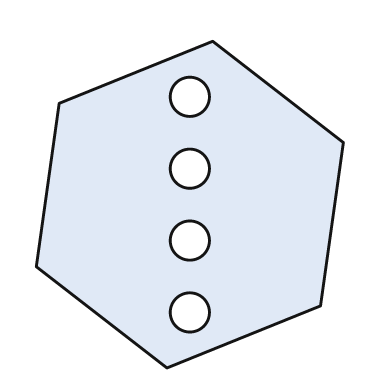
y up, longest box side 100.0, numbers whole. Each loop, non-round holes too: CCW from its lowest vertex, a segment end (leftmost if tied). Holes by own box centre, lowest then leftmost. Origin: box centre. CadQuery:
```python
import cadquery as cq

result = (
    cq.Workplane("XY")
    .moveTo(-7.0, -50.0)
    .lineTo(40.0, -31.0)
    .lineTo(47.0, 19.0)
    .lineTo(7.0, 50.0)
    .lineTo(-40.0, 31.0)
    .lineTo(-47.0, -19.0)
    .close()
    .moveTo(0.0, -33.0)
    .circle(6.0)
    .moveTo(0.0, -11.0)
    .circle(6.0)
    .moveTo(0.0, 11.0)
    .circle(6.0)
    .moveTo(0.0, 33.0)
    .circle(6.0)
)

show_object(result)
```